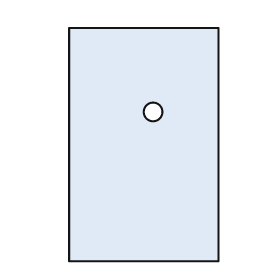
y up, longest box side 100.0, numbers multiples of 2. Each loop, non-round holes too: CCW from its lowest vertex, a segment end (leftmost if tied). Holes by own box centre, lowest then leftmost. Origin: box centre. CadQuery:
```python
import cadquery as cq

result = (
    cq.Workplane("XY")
    .moveTo(-32.0, -50.0)
    .lineTo(32.0, -50.0)
    .lineTo(32.0, 50.0)
    .lineTo(-32.0, 50.0)
    .close()
    .moveTo(4.0, 14.0)
    .circle(4.0)
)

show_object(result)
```